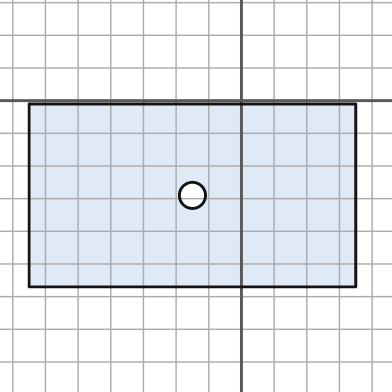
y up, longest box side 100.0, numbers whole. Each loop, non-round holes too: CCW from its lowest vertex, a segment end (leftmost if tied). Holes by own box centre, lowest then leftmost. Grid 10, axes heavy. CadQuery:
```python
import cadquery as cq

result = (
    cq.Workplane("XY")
    .moveTo(-65.0, -57.0)
    .lineTo(35.0, -57.0)
    .lineTo(35.0, -1.0)
    .lineTo(-65.0, -1.0)
    .close()
    .moveTo(-15.0, -29.0)
    .circle(4.0)
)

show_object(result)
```